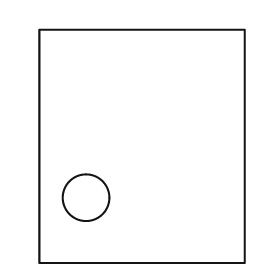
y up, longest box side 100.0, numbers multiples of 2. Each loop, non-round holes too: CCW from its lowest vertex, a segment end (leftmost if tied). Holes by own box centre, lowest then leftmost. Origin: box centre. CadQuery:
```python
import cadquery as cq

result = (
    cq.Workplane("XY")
    .moveTo(-44.0, -50.0)
    .lineTo(44.0, -50.0)
    .lineTo(44.0, 50.0)
    .lineTo(-44.0, 50.0)
    .close()
    .moveTo(-24.0, -22.0)
    .circle(10.0)
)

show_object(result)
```